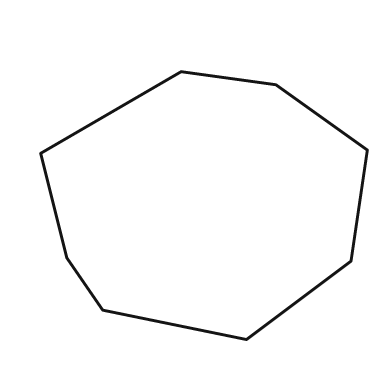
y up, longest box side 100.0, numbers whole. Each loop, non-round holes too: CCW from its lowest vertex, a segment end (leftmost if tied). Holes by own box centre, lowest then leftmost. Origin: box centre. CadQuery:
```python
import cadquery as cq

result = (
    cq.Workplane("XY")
    .moveTo(13.0, -41.0)
    .lineTo(45.0, -17.0)
    .lineTo(50.0, 17.0)
    .lineTo(22.0, 37.0)
    .lineTo(-7.0, 41.0)
    .lineTo(-50.0, 16.0)
    .lineTo(-42.0, -16.0)
    .lineTo(-31.0, -32.0)
    .close()
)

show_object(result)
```